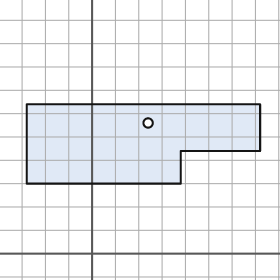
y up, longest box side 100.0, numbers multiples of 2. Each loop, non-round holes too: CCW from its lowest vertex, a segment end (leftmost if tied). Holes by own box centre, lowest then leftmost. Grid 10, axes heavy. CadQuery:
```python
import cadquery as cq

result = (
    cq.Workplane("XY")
    .moveTo(-28.0, 30.0)
    .lineTo(38.0, 30.0)
    .lineTo(38.0, 44.0)
    .lineTo(72.0, 44.0)
    .lineTo(72.0, 64.0)
    .lineTo(-28.0, 64.0)
    .close()
    .moveTo(24.0, 56.0)
    .circle(2.0)
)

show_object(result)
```